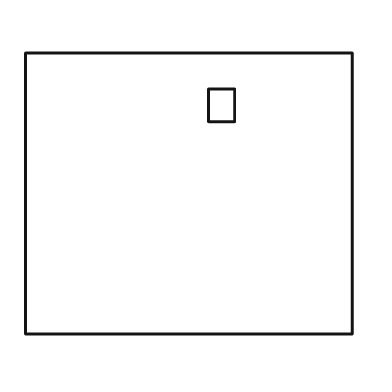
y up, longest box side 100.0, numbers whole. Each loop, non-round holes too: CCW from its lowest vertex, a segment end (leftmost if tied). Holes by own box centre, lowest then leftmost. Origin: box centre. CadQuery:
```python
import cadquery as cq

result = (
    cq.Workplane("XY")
    .moveTo(-50.0, -43.0)
    .lineTo(50.0, -43.0)
    .lineTo(50.0, 43.0)
    .lineTo(-50.0, 43.0)
    .close()
    .moveTo(6.0, 22.0)
    .lineTo(14.0, 22.0)
    .lineTo(14.0, 32.0)
    .lineTo(6.0, 32.0)
    .close()
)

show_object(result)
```